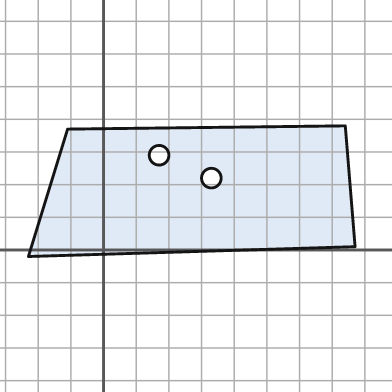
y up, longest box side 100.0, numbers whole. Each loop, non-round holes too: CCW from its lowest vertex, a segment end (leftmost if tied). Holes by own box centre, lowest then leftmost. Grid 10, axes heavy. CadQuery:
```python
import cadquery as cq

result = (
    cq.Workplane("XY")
    .moveTo(-23.0, -2.0)
    .lineTo(77.0, 1.0)
    .lineTo(74.0, 38.0)
    .lineTo(-11.0, 37.0)
    .close()
    .moveTo(33.0, 22.0)
    .circle(3.0)
    .moveTo(17.0, 29.0)
    .circle(3.0)
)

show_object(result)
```